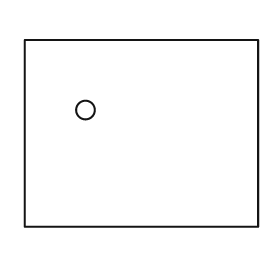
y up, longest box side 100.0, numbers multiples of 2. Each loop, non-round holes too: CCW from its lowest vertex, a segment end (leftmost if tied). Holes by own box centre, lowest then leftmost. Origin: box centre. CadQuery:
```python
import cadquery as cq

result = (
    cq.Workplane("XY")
    .moveTo(-50.0, -40.0)
    .lineTo(50.0, -40.0)
    .lineTo(50.0, 40.0)
    .lineTo(-50.0, 40.0)
    .close()
    .moveTo(-24.0, 10.0)
    .circle(4.0)
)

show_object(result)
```